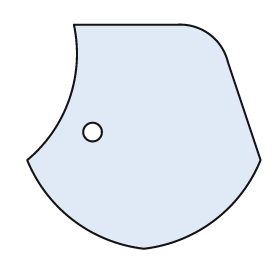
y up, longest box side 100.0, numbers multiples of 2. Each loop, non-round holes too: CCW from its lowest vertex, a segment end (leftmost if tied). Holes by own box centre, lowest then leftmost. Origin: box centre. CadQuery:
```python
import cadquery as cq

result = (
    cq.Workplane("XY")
    .moveTo(0.0, -48.0)
    .threePointArc((30.0, -36.0), (50.0, -10.0))
    .lineTo(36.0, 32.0)
    .threePointArc((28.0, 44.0), (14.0, 48.0))
    .lineTo(-30.0, 48.0)
    .threePointArc((-32.0, 16.0), (-50.0, -10.0))
    .threePointArc((-30.0, -36.0), (0.0, -48.0))
    .close()
    .moveTo(-22.0, 2.0)
    .circle(4.0)
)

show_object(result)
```